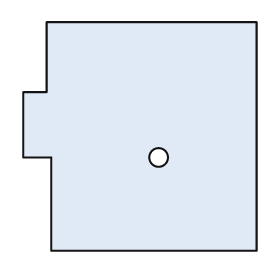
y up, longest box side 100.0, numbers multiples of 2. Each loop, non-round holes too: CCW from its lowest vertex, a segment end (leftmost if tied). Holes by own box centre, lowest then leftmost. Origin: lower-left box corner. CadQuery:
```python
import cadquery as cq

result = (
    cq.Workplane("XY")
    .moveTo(12.0, 0.0)
    .lineTo(100.0, 0.0)
    .lineTo(100.0, 98.0)
    .lineTo(10.0, 98.0)
    .lineTo(10.0, 68.0)
    .lineTo(0.0, 68.0)
    .lineTo(0.0, 40.0)
    .lineTo(12.0, 40.0)
    .close()
    .moveTo(58.0, 40.0)
    .circle(4.0)
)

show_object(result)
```